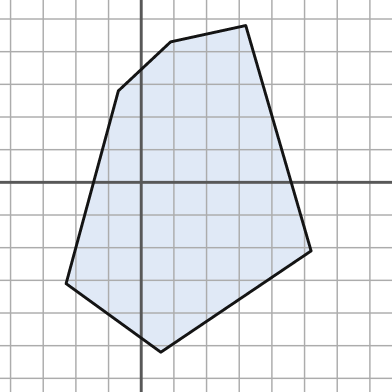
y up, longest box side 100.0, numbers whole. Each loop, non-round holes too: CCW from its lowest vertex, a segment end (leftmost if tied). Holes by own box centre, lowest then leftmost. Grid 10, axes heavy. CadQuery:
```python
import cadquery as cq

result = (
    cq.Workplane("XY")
    .moveTo(6.0, -52.0)
    .lineTo(52.0, -21.0)
    .lineTo(32.0, 48.0)
    .lineTo(9.0, 43.0)
    .lineTo(-7.0, 28.0)
    .lineTo(-23.0, -31.0)
    .close()
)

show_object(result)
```